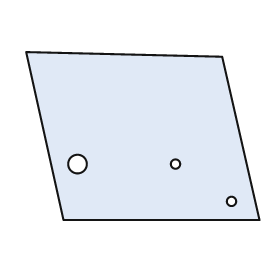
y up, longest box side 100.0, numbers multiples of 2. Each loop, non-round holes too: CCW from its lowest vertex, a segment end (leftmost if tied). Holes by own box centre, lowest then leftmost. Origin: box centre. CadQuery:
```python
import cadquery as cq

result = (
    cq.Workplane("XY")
    .moveTo(-34.0, -36.0)
    .lineTo(50.0, -36.0)
    .lineTo(34.0, 34.0)
    .lineTo(-50.0, 36.0)
    .close()
    .moveTo(38.0, -28.0)
    .circle(2.0)
    .moveTo(-28.0, -12.0)
    .circle(4.0)
    .moveTo(14.0, -12.0)
    .circle(2.0)
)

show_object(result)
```